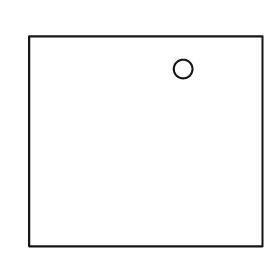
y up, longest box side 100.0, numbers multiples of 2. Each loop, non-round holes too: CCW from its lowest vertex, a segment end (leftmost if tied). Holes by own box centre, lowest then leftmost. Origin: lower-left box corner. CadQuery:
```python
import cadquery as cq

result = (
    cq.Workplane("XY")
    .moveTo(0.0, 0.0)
    .lineTo(100.0, 0.0)
    .lineTo(100.0, 90.0)
    .lineTo(0.0, 90.0)
    .close()
    .moveTo(66.0, 76.0)
    .circle(4.0)
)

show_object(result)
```